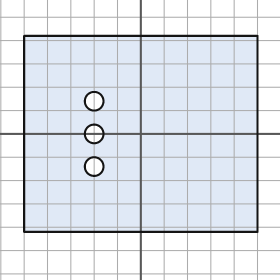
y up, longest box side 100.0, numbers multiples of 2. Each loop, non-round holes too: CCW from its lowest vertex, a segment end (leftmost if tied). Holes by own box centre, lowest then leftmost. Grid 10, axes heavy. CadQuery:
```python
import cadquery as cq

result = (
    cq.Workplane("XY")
    .moveTo(-50.0, -42.0)
    .lineTo(50.0, -42.0)
    .lineTo(50.0, 42.0)
    .lineTo(-50.0, 42.0)
    .close()
    .moveTo(-20.0, -14.0)
    .circle(4.0)
    .moveTo(-20.0, 0.0)
    .circle(4.0)
    .moveTo(-20.0, 14.0)
    .circle(4.0)
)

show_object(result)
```